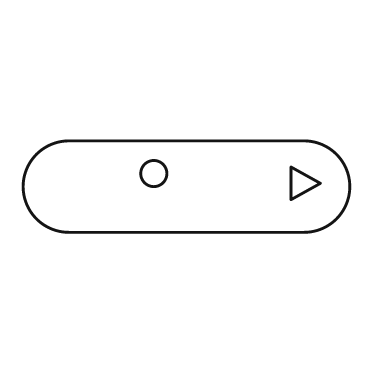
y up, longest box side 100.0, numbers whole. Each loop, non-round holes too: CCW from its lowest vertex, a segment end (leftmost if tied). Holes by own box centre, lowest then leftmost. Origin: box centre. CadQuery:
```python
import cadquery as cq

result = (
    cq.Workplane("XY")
    .moveTo(-36.0, -14.0)
    .lineTo(36.0, -14.0)
    .threePointArc((50.0, 0.0), (36.0, 14.0))
    .lineTo(-36.0, 14.0)
    .threePointArc((-50.0, 0.0), (-36.0, -14.0))
    .close()
    .moveTo(32.0, -4.0)
    .lineTo(41.0, 1.0)
    .lineTo(32.0, 6.0)
    .close()
    .moveTo(-10.0, 4.0)
    .circle(4.0)
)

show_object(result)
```